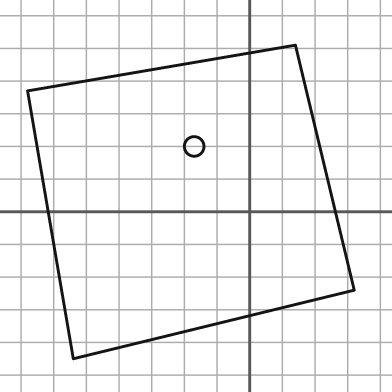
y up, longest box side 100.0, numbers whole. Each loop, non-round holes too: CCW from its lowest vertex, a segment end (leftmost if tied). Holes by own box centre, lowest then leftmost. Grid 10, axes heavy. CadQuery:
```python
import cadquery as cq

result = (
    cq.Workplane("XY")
    .moveTo(-54.0, -45.0)
    .lineTo(32.0, -24.0)
    .lineTo(14.0, 51.0)
    .lineTo(-68.0, 37.0)
    .close()
    .moveTo(-17.0, 20.0)
    .circle(3.0)
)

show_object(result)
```